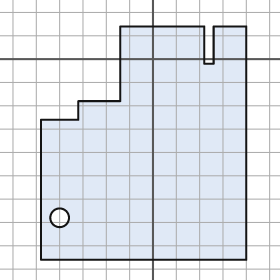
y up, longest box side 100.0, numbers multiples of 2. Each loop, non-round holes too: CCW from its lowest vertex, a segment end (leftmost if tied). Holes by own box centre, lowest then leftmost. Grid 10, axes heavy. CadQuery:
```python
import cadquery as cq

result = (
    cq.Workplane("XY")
    .moveTo(-48.0, -86.0)
    .lineTo(40.0, -86.0)
    .lineTo(40.0, 14.0)
    .lineTo(26.0, 14.0)
    .lineTo(26.0, -2.0)
    .lineTo(22.0, -2.0)
    .lineTo(22.0, 14.0)
    .lineTo(-14.0, 14.0)
    .lineTo(-14.0, -18.0)
    .lineTo(-32.0, -18.0)
    .lineTo(-32.0, -26.0)
    .lineTo(-48.0, -26.0)
    .close()
    .moveTo(-40.0, -68.0)
    .circle(4.0)
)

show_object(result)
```